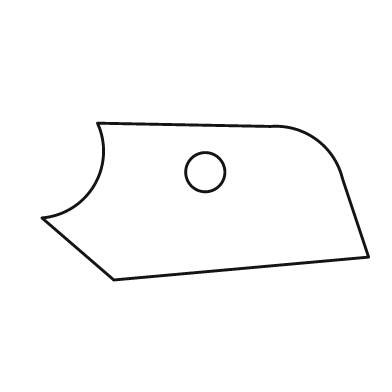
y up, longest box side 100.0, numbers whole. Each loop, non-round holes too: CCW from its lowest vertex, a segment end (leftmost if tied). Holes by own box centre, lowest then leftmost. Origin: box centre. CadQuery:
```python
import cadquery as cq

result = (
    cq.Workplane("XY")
    .moveTo(-28.0, -24.0)
    .lineTo(50.0, -17.0)
    .lineTo(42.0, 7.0)
    .threePointArc((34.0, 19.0), (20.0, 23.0))
    .lineTo(-33.0, 24.0)
    .threePointArc((-34.0, 5.0), (-50.0, -5.0))
    .close()
    .moveTo(0.0, 9.0)
    .circle(6.0)
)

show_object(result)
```